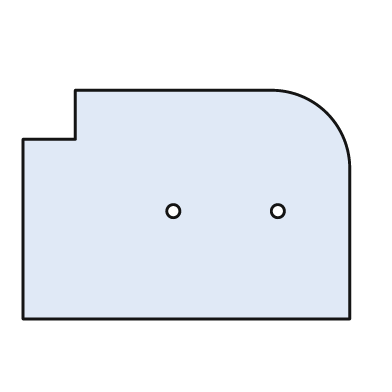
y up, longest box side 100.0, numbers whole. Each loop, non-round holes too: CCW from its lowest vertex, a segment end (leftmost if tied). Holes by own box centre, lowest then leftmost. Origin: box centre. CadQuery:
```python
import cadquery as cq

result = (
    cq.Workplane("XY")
    .moveTo(-50.0, -35.0)
    .lineTo(50.0, -35.0)
    .lineTo(50.0, 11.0)
    .threePointArc((43.0, 28.0), (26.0, 35.0))
    .lineTo(-34.0, 35.0)
    .lineTo(-34.0, 20.0)
    .lineTo(-50.0, 20.0)
    .close()
    .moveTo(-4.0, -2.0)
    .circle(2.0)
    .moveTo(28.0, -2.0)
    .circle(2.0)
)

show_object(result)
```